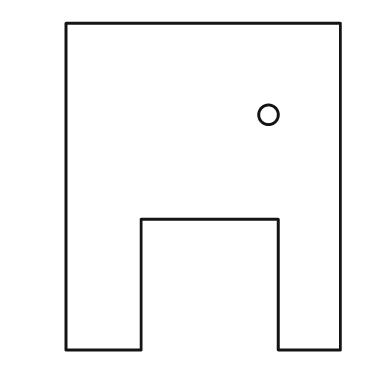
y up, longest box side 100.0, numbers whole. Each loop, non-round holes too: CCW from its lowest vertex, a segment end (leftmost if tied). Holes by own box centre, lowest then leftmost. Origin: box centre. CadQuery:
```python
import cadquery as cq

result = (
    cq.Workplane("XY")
    .moveTo(-42.0, -50.0)
    .lineTo(-19.0, -50.0)
    .lineTo(-19.0, -10.0)
    .lineTo(23.0, -10.0)
    .lineTo(23.0, -50.0)
    .lineTo(42.0, -50.0)
    .lineTo(42.0, 50.0)
    .lineTo(-42.0, 50.0)
    .close()
    .moveTo(20.0, 22.0)
    .circle(3.0)
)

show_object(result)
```